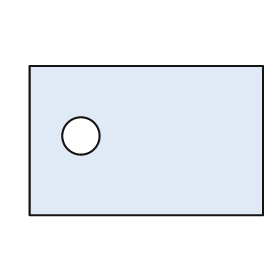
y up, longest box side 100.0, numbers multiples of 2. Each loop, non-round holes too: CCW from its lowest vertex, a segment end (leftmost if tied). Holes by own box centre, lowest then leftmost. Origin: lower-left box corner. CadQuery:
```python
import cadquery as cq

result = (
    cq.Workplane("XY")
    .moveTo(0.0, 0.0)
    .lineTo(100.0, 0.0)
    .lineTo(100.0, 64.0)
    .lineTo(0.0, 64.0)
    .close()
    .moveTo(22.0, 34.0)
    .circle(8.0)
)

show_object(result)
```